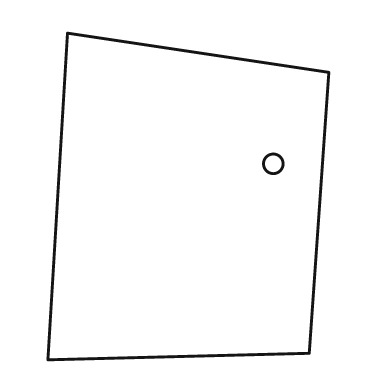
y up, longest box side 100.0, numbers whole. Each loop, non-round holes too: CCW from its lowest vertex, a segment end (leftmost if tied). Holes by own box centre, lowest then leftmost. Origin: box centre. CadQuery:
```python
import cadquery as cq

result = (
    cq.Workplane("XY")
    .moveTo(-43.0, -50.0)
    .lineTo(37.0, -48.0)
    .lineTo(43.0, 38.0)
    .lineTo(-37.0, 50.0)
    .close()
    .moveTo(26.0, 10.0)
    .circle(3.0)
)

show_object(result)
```